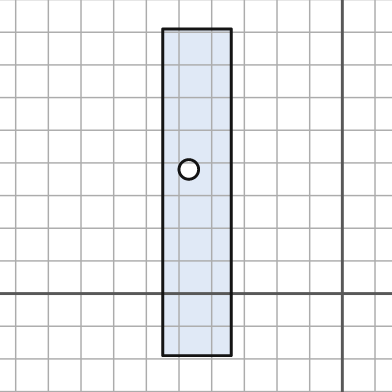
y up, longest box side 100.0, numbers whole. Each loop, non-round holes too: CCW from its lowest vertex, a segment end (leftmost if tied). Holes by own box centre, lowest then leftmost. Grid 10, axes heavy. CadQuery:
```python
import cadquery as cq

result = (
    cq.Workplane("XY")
    .moveTo(-55.0, -19.0)
    .lineTo(-34.0, -19.0)
    .lineTo(-34.0, 81.0)
    .lineTo(-55.0, 81.0)
    .close()
    .moveTo(-47.0, 38.0)
    .circle(3.0)
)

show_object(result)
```